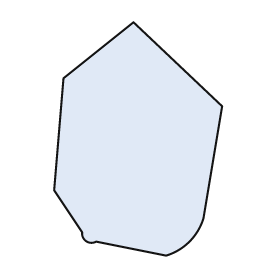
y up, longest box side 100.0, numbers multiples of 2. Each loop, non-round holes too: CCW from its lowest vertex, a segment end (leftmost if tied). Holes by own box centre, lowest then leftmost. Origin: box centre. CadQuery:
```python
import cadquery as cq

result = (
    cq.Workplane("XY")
    .moveTo(12.0, -50.0)
    .threePointArc((22.0, -44.0), (28.0, -34.0))
    .lineTo(36.0, 14.0)
    .lineTo(-2.0, 50.0)
    .lineTo(-32.0, 26.0)
    .lineTo(-36.0, -22.0)
    .lineTo(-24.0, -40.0)
    .threePointArc((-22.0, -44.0), (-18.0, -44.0))
    .close()
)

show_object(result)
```